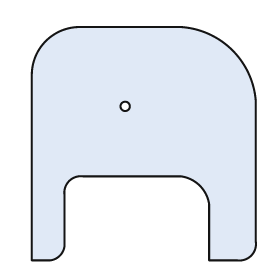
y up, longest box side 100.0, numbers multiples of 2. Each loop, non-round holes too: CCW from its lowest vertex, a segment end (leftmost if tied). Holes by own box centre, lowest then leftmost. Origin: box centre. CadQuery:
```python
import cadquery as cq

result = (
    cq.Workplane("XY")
    .moveTo(-48.0, -50.0)
    .lineTo(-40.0, -50.0)
    .threePointArc((-36.0, -48.0), (-34.0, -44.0))
    .lineTo(-34.0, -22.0)
    .threePointArc((-32.0, -16.0), (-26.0, -14.0))
    .lineTo(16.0, -14.0)
    .threePointArc((24.0, -18.0), (28.0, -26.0))
    .lineTo(28.0, -50.0)
    .lineTo(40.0, -50.0)
    .threePointArc((46.0, -48.0), (48.0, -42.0))
    .lineTo(48.0, 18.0)
    .threePointArc((38.0, 40.0), (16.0, 50.0))
    .lineTo(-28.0, 50.0)
    .threePointArc((-42.0, 44.0), (-48.0, 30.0))
    .close()
    .moveTo(-8.0, 16.0)
    .circle(2.0)
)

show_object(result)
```